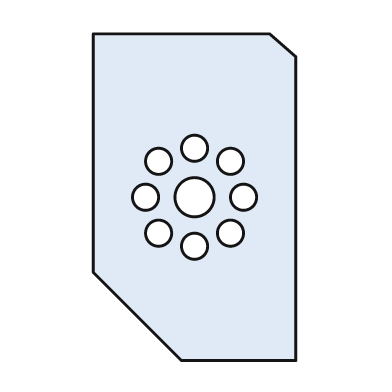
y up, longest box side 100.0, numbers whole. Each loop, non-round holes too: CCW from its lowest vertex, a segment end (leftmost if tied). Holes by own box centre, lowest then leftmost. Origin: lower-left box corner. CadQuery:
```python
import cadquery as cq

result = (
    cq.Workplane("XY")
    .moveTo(27.0, 0.0)
    .lineTo(62.0, 0.0)
    .lineTo(62.0, 93.0)
    .lineTo(54.0, 100.0)
    .lineTo(0.0, 100.0)
    .lineTo(0.0, 27.0)
    .close()
    .moveTo(31.0, 35.0)
    .circle(4.0)
    .moveTo(20.0, 39.0)
    .circle(4.0)
    .moveTo(42.0, 39.0)
    .circle(4.0)
    .moveTo(16.0, 50.0)
    .circle(4.0)
    .moveTo(31.0, 50.0)
    .circle(6.0)
    .moveTo(46.0, 50.0)
    .circle(4.0)
    .moveTo(20.0, 61.0)
    .circle(4.0)
    .moveTo(42.0, 61.0)
    .circle(4.0)
    .moveTo(31.0, 65.0)
    .circle(4.0)
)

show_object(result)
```